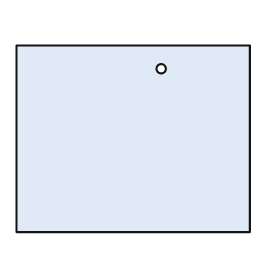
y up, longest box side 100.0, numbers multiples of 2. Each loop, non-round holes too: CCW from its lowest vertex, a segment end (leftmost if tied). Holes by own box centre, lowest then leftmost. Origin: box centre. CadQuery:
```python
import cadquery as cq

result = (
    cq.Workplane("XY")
    .moveTo(-50.0, -40.0)
    .lineTo(50.0, -40.0)
    .lineTo(50.0, 40.0)
    .lineTo(-50.0, 40.0)
    .close()
    .moveTo(12.0, 30.0)
    .circle(2.0)
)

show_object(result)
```